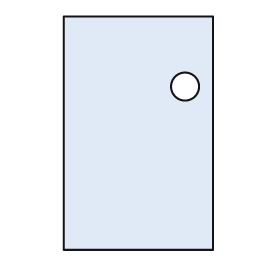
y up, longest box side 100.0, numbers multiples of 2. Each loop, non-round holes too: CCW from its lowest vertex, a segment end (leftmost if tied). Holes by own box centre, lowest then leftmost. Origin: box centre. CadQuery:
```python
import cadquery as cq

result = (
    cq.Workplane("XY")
    .moveTo(-32.0, -50.0)
    .lineTo(32.0, -50.0)
    .lineTo(32.0, 50.0)
    .lineTo(-32.0, 50.0)
    .close()
    .moveTo(20.0, 20.0)
    .circle(6.0)
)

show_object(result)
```